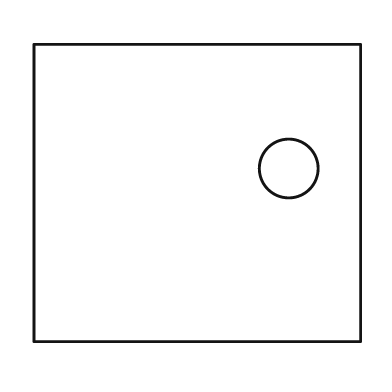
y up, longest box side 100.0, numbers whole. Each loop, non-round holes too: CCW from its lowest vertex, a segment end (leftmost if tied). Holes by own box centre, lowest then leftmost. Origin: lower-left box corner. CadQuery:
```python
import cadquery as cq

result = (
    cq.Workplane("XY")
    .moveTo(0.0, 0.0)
    .lineTo(100.0, 0.0)
    .lineTo(100.0, 91.0)
    .lineTo(0.0, 91.0)
    .close()
    .moveTo(78.0, 53.0)
    .circle(9.0)
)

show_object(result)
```